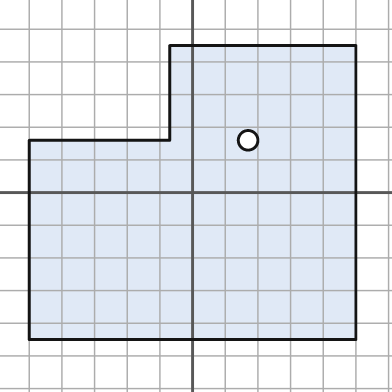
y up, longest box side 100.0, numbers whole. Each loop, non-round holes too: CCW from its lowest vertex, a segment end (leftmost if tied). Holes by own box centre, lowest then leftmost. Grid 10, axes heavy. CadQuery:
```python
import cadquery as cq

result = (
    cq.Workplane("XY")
    .moveTo(-50.0, -45.0)
    .lineTo(50.0, -45.0)
    .lineTo(50.0, 45.0)
    .lineTo(-7.0, 45.0)
    .lineTo(-7.0, 16.0)
    .lineTo(-50.0, 16.0)
    .close()
    .moveTo(17.0, 16.0)
    .circle(3.0)
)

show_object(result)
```